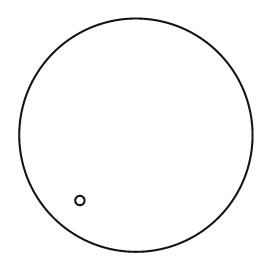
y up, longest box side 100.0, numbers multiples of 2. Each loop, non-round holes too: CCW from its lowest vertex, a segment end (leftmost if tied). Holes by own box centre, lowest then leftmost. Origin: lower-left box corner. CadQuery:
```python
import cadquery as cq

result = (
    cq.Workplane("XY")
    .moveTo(50.0, 50.0)
    .circle(50.0)
    .moveTo(26.0, 22.0)
    .circle(2.0)
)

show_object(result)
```